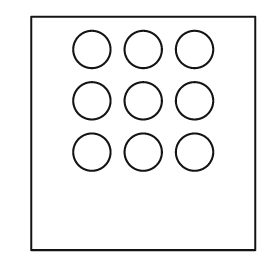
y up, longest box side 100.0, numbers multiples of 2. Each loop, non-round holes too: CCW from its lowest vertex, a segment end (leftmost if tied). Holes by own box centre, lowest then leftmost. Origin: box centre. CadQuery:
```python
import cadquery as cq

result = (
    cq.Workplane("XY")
    .moveTo(-48.0, -50.0)
    .lineTo(48.0, -50.0)
    .lineTo(48.0, 50.0)
    .lineTo(-48.0, 50.0)
    .close()
    .moveTo(-22.0, -8.0)
    .circle(8.0)
    .moveTo(0.0, -8.0)
    .circle(8.0)
    .moveTo(22.0, -8.0)
    .circle(8.0)
    .moveTo(-22.0, 14.0)
    .circle(8.0)
    .moveTo(0.0, 14.0)
    .circle(8.0)
    .moveTo(22.0, 14.0)
    .circle(8.0)
    .moveTo(-22.0, 36.0)
    .circle(8.0)
    .moveTo(0.0, 36.0)
    .circle(8.0)
    .moveTo(22.0, 36.0)
    .circle(8.0)
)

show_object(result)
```